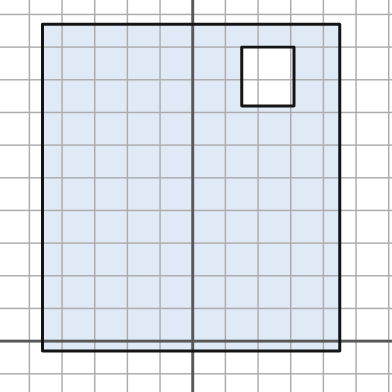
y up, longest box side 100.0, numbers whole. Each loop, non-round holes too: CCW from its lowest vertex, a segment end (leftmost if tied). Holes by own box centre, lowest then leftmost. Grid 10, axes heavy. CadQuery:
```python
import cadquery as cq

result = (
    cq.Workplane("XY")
    .moveTo(-46.0, -3.0)
    .lineTo(45.0, -3.0)
    .lineTo(45.0, 97.0)
    .lineTo(-46.0, 97.0)
    .close()
    .moveTo(15.0, 72.0)
    .lineTo(31.0, 72.0)
    .lineTo(31.0, 90.0)
    .lineTo(15.0, 90.0)
    .close()
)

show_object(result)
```